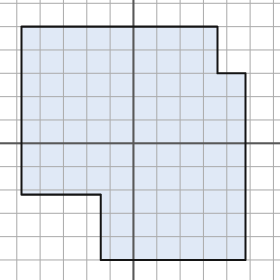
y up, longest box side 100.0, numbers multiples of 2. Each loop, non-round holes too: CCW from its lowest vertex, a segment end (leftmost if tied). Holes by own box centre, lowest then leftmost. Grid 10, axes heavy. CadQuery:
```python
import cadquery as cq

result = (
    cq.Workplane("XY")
    .moveTo(-14.0, -50.0)
    .lineTo(48.0, -50.0)
    .lineTo(48.0, 30.0)
    .lineTo(36.0, 30.0)
    .lineTo(36.0, 50.0)
    .lineTo(-48.0, 50.0)
    .lineTo(-48.0, -22.0)
    .lineTo(-14.0, -22.0)
    .close()
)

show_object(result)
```